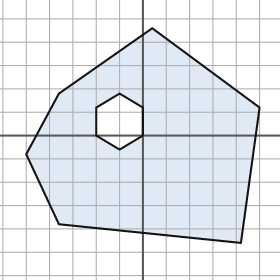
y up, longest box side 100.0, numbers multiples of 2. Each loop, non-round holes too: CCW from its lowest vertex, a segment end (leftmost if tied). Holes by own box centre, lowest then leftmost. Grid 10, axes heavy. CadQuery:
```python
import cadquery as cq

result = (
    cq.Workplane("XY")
    .moveTo(42.0, -46.0)
    .lineTo(50.0, 12.0)
    .lineTo(4.0, 46.0)
    .lineTo(-36.0, 18.0)
    .lineTo(-50.0, -8.0)
    .lineTo(-36.0, -38.0)
    .close()
    .moveTo(-10.0, -6.0)
    .lineTo(0.0, 0.0)
    .lineTo(0.0, 12.0)
    .lineTo(-10.0, 18.0)
    .lineTo(-20.0, 12.0)
    .lineTo(-20.0, 0.0)
    .close()
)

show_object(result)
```